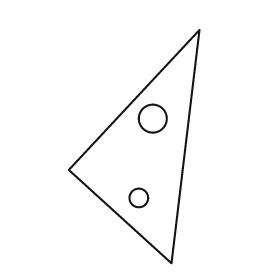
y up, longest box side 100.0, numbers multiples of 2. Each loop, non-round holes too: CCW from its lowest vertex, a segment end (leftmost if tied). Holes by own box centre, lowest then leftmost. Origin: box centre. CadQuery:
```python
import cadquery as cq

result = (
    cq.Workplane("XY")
    .moveTo(16.0, -50.0)
    .lineTo(28.0, 50.0)
    .lineTo(-28.0, -10.0)
    .close()
    .moveTo(2.0, -22.0)
    .circle(4.0)
    .moveTo(8.0, 12.0)
    .circle(6.0)
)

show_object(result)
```